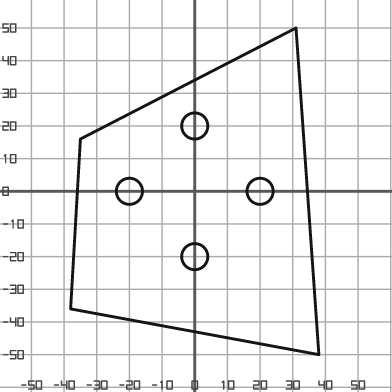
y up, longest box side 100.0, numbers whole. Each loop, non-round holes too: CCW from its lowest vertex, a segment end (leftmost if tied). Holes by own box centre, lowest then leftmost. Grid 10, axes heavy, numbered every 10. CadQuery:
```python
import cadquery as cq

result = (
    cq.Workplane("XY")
    .moveTo(38.0, -50.0)
    .lineTo(31.0, 50.0)
    .lineTo(-35.0, 16.0)
    .lineTo(-38.0, -36.0)
    .close()
    .moveTo(0.0, -20.0)
    .circle(4.0)
    .moveTo(-20.0, 0.0)
    .circle(4.0)
    .moveTo(20.0, 0.0)
    .circle(4.0)
    .moveTo(0.0, 20.0)
    .circle(4.0)
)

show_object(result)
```